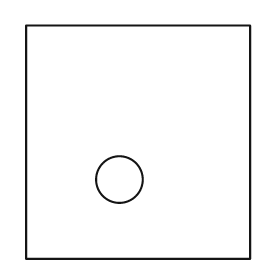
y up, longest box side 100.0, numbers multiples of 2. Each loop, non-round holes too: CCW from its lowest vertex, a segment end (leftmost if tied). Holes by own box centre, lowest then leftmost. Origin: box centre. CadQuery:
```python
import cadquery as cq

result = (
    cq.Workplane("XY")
    .moveTo(-48.0, -50.0)
    .lineTo(48.0, -50.0)
    .lineTo(48.0, 50.0)
    .lineTo(-48.0, 50.0)
    .close()
    .moveTo(-8.0, -16.0)
    .circle(10.0)
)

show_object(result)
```